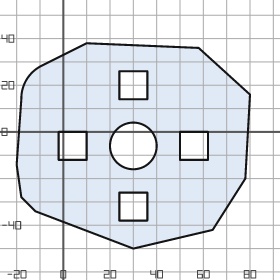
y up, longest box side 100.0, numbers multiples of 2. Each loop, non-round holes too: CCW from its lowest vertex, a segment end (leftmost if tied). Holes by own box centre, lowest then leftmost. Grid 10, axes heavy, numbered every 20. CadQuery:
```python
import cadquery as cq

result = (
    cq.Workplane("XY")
    .moveTo(30.0, -50.0)
    .lineTo(64.0, -42.0)
    .lineTo(78.0, -20.0)
    .lineTo(80.0, 16.0)
    .lineTo(58.0, 36.0)
    .lineTo(10.0, 38.0)
    .lineTo(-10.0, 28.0)
    .threePointArc((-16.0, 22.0), (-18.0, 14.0))
    .lineTo(-20.0, -14.0)
    .lineTo(-18.0, -28.0)
    .lineTo(-12.0, -34.0)
    .close()
    .moveTo(24.0, -38.0)
    .lineTo(36.0, -38.0)
    .lineTo(36.0, -26.0)
    .lineTo(24.0, -26.0)
    .close()
    .moveTo(-2.0, -12.0)
    .lineTo(10.0, -12.0)
    .lineTo(10.0, 0.0)
    .lineTo(-2.0, 0.0)
    .close()
    .moveTo(30.0, -6.0)
    .circle(10.0)
    .moveTo(50.0, -12.0)
    .lineTo(62.0, -12.0)
    .lineTo(62.0, 0.0)
    .lineTo(50.0, 0.0)
    .close()
    .moveTo(24.0, 14.0)
    .lineTo(36.0, 14.0)
    .lineTo(36.0, 26.0)
    .lineTo(24.0, 26.0)
    .close()
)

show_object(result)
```